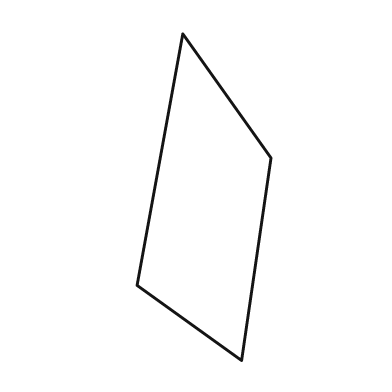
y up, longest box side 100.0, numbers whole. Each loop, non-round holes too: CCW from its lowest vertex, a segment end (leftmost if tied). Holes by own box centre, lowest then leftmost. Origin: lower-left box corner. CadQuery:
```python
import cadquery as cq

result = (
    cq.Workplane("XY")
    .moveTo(32.0, 0.0)
    .lineTo(41.0, 62.0)
    .lineTo(14.0, 100.0)
    .lineTo(0.0, 23.0)
    .close()
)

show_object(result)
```